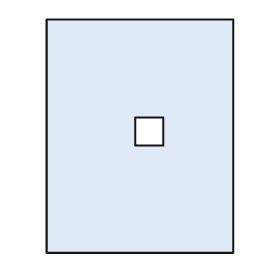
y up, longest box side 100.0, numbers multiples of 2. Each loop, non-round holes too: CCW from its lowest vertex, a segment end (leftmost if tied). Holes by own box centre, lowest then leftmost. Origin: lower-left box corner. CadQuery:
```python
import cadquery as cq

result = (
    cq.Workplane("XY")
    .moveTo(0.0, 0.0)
    .lineTo(80.0, 0.0)
    .lineTo(80.0, 100.0)
    .lineTo(0.0, 100.0)
    .close()
    .moveTo(38.0, 46.0)
    .lineTo(50.0, 46.0)
    .lineTo(50.0, 58.0)
    .lineTo(38.0, 58.0)
    .close()
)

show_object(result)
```